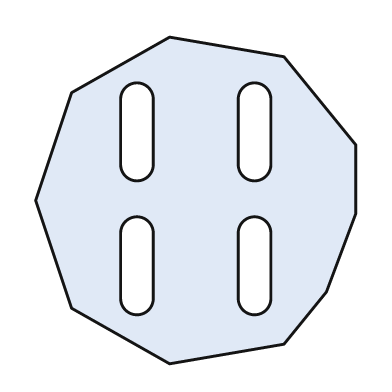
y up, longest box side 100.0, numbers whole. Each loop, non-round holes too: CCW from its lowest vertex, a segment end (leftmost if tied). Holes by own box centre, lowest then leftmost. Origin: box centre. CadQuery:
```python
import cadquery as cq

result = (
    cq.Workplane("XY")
    .moveTo(-8.0, -50.0)
    .lineTo(27.0, -44.0)
    .lineTo(40.0, -28.0)
    .lineTo(49.0, -4.0)
    .lineTo(49.0, 17.0)
    .lineTo(27.0, 44.0)
    .lineTo(-8.0, 50.0)
    .lineTo(-38.0, 33.0)
    .lineTo(-49.0, 0.0)
    .lineTo(-38.0, -33.0)
    .close()
    .moveTo(-23.0, -30.0)
    .threePointArc((-18.0, -35.0), (-13.0, -30.0))
    .lineTo(-13.0, -10.0)
    .threePointArc((-18.0, -5.0), (-23.0, -10.0))
    .close()
    .moveTo(13.0, -30.0)
    .threePointArc((18.0, -35.0), (23.0, -30.0))
    .lineTo(23.0, -10.0)
    .threePointArc((18.0, -5.0), (13.0, -10.0))
    .close()
    .moveTo(-23.0, 11.0)
    .threePointArc((-18.0, 6.0), (-13.0, 11.0))
    .lineTo(-13.0, 31.0)
    .threePointArc((-18.0, 36.0), (-23.0, 31.0))
    .close()
    .moveTo(13.0, 11.0)
    .threePointArc((18.0, 6.0), (23.0, 11.0))
    .lineTo(23.0, 31.0)
    .threePointArc((18.0, 36.0), (13.0, 31.0))
    .close()
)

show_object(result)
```